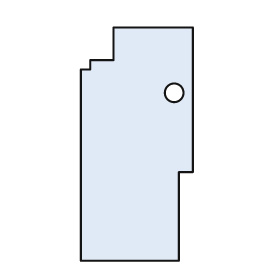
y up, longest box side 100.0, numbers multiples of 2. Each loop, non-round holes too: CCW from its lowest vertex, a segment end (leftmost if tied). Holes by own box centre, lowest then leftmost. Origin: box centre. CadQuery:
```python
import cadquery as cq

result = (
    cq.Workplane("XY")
    .moveTo(-24.0, -50.0)
    .lineTo(18.0, -50.0)
    .lineTo(18.0, -12.0)
    .lineTo(24.0, -12.0)
    .lineTo(24.0, 50.0)
    .lineTo(-10.0, 50.0)
    .lineTo(-10.0, 36.0)
    .lineTo(-20.0, 36.0)
    .lineTo(-20.0, 32.0)
    .lineTo(-24.0, 32.0)
    .close()
    .moveTo(16.0, 22.0)
    .circle(4.0)
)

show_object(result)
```